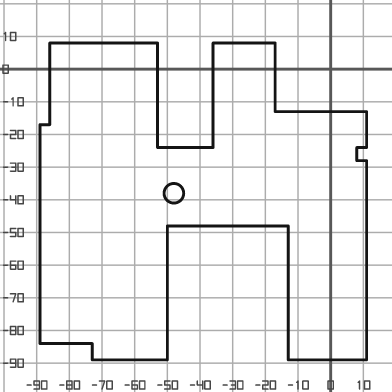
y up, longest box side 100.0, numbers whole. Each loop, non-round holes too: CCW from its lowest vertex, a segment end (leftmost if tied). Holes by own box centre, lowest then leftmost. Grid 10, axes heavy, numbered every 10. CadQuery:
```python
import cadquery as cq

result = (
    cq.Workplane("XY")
    .moveTo(-73.0, -89.0)
    .lineTo(-50.0, -89.0)
    .lineTo(-50.0, -48.0)
    .lineTo(-13.0, -48.0)
    .lineTo(-13.0, -89.0)
    .lineTo(11.0, -89.0)
    .lineTo(11.0, -28.0)
    .lineTo(8.0, -28.0)
    .lineTo(8.0, -24.0)
    .lineTo(11.0, -24.0)
    .lineTo(11.0, -13.0)
    .lineTo(-17.0, -13.0)
    .lineTo(-17.0, 8.0)
    .lineTo(-36.0, 8.0)
    .lineTo(-36.0, -24.0)
    .lineTo(-53.0, -24.0)
    .lineTo(-53.0, 8.0)
    .lineTo(-86.0, 8.0)
    .lineTo(-86.0, -17.0)
    .lineTo(-89.0, -17.0)
    .lineTo(-89.0, -84.0)
    .lineTo(-73.0, -84.0)
    .close()
    .moveTo(-48.0, -38.0)
    .circle(3.0)
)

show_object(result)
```